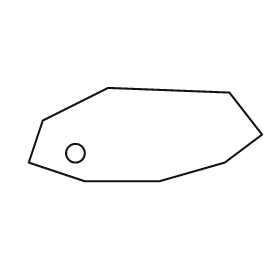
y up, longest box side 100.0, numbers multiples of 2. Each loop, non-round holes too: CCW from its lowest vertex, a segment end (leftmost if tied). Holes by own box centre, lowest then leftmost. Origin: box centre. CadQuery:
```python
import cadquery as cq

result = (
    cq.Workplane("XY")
    .moveTo(-26.0, -20.0)
    .lineTo(6.0, -20.0)
    .lineTo(34.0, -12.0)
    .lineTo(50.0, 0.0)
    .lineTo(36.0, 18.0)
    .lineTo(-16.0, 20.0)
    .lineTo(-44.0, 6.0)
    .lineTo(-50.0, -12.0)
    .close()
    .moveTo(-30.0, -8.0)
    .circle(4.0)
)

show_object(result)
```